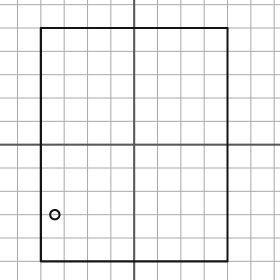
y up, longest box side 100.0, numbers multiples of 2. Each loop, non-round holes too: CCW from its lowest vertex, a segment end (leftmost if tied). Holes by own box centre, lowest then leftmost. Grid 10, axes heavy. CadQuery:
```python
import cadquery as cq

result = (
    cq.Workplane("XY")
    .moveTo(-40.0, -50.0)
    .lineTo(40.0, -50.0)
    .lineTo(40.0, 50.0)
    .lineTo(-40.0, 50.0)
    .close()
    .moveTo(-34.0, -30.0)
    .circle(2.0)
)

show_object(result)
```